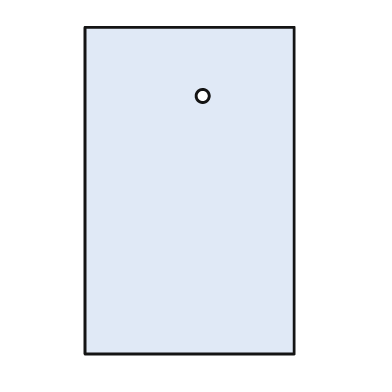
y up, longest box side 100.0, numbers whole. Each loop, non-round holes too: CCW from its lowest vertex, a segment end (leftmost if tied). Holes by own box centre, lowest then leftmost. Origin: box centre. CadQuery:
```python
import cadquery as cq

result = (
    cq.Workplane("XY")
    .moveTo(-32.0, -50.0)
    .lineTo(32.0, -50.0)
    .lineTo(32.0, 50.0)
    .lineTo(-32.0, 50.0)
    .close()
    .moveTo(4.0, 29.0)
    .circle(2.0)
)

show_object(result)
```